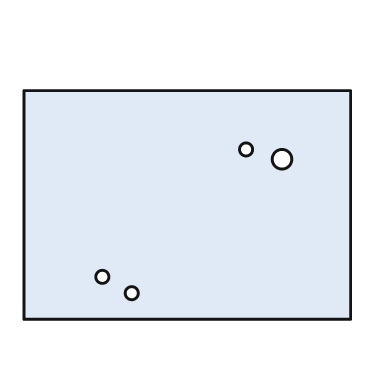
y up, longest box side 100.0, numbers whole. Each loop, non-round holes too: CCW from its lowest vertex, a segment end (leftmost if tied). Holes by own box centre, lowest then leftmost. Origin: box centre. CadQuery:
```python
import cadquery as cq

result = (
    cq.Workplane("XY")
    .moveTo(-50.0, -35.0)
    .lineTo(50.0, -35.0)
    .lineTo(50.0, 35.0)
    .lineTo(-50.0, 35.0)
    .close()
    .moveTo(-17.0, -27.0)
    .circle(2.0)
    .moveTo(-26.0, -22.0)
    .circle(2.0)
    .moveTo(29.0, 14.0)
    .circle(3.0)
    .moveTo(18.0, 17.0)
    .circle(2.0)
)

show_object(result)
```